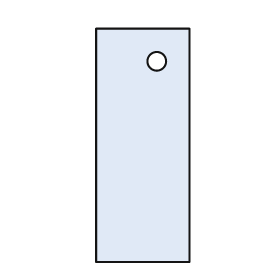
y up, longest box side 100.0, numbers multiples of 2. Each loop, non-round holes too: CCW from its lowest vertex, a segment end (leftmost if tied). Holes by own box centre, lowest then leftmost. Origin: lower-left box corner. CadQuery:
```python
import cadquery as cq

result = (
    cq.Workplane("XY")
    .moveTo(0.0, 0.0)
    .lineTo(40.0, 0.0)
    .lineTo(40.0, 100.0)
    .lineTo(0.0, 100.0)
    .close()
    .moveTo(26.0, 86.0)
    .circle(4.0)
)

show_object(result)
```